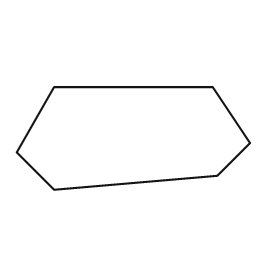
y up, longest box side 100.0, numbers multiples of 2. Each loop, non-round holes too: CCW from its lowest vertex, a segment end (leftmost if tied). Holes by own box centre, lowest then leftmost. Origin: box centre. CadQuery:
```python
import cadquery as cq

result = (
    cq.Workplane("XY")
    .moveTo(-34.0, -22.0)
    .lineTo(36.0, -16.0)
    .lineTo(50.0, -2.0)
    .lineTo(34.0, 22.0)
    .lineTo(-34.0, 22.0)
    .lineTo(-50.0, -6.0)
    .close()
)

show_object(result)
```